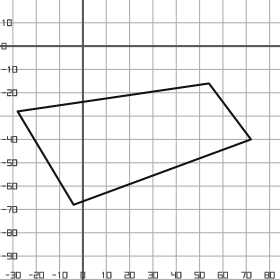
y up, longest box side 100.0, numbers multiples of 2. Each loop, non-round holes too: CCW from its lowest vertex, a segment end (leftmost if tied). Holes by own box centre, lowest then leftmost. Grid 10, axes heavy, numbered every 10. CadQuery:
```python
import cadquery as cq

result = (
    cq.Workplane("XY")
    .moveTo(-4.0, -68.0)
    .lineTo(72.0, -40.0)
    .lineTo(54.0, -16.0)
    .lineTo(-28.0, -28.0)
    .close()
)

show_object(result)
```